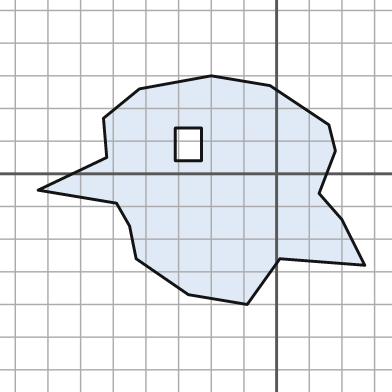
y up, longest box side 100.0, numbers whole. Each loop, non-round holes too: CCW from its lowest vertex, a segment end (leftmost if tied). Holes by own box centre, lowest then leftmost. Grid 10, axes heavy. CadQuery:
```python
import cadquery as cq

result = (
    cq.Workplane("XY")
    .moveTo(-9.0, -40.0)
    .lineTo(1.0, -26.0)
    .lineTo(27.0, -28.0)
    .lineTo(20.0, -14.0)
    .lineTo(13.0, -6.0)
    .lineTo(18.0, 7.0)
    .lineTo(16.0, 15.0)
    .lineTo(-2.0, 27.0)
    .lineTo(-20.0, 30.0)
    .lineTo(-42.0, 26.0)
    .lineTo(-53.0, 17.0)
    .lineTo(-52.0, 5.0)
    .lineTo(-73.0, -5.0)
    .lineTo(-49.0, -9.0)
    .lineTo(-45.0, -16.0)
    .lineTo(-43.0, -26.0)
    .lineTo(-27.0, -37.0)
    .close()
    .moveTo(-31.0, 4.0)
    .lineTo(-23.0, 4.0)
    .lineTo(-23.0, 14.0)
    .lineTo(-31.0, 14.0)
    .close()
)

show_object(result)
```